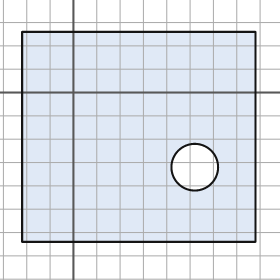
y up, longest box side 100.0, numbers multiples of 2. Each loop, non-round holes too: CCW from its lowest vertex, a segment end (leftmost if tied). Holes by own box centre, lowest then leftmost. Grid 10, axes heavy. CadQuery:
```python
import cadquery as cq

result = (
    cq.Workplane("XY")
    .moveTo(-22.0, -64.0)
    .lineTo(78.0, -64.0)
    .lineTo(78.0, 26.0)
    .lineTo(-22.0, 26.0)
    .close()
    .moveTo(52.0, -32.0)
    .circle(10.0)
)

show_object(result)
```